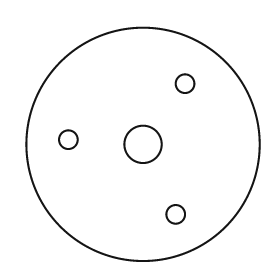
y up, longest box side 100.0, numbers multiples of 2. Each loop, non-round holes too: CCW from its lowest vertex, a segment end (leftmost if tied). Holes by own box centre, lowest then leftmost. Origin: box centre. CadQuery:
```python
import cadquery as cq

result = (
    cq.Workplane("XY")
    .moveTo(0.0, 0.0)
    .circle(50.0)
    .moveTo(14.0, -30.0)
    .circle(4.0)
    .moveTo(0.0, 0.0)
    .circle(8.0)
    .moveTo(-32.0, 2.0)
    .circle(4.0)
    .moveTo(18.0, 26.0)
    .circle(4.0)
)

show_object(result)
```